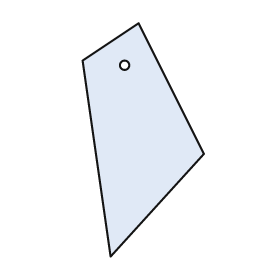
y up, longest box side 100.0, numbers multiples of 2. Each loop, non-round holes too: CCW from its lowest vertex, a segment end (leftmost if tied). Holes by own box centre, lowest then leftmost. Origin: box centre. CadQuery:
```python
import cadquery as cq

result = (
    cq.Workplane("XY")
    .moveTo(-14.0, -50.0)
    .lineTo(26.0, -6.0)
    .lineTo(-2.0, 50.0)
    .lineTo(-26.0, 34.0)
    .close()
    .moveTo(-8.0, 32.0)
    .circle(2.0)
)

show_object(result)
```